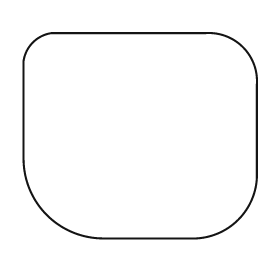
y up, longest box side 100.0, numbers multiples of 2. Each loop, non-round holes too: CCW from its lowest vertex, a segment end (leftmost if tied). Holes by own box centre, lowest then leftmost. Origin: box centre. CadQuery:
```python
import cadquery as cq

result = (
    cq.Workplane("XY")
    .moveTo(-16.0, -44.0)
    .lineTo(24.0, -44.0)
    .threePointArc((42.0, -36.0), (50.0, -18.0))
    .lineTo(50.0, 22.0)
    .threePointArc((44.0, 38.0), (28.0, 44.0))
    .lineTo(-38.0, 44.0)
    .threePointArc((-46.0, 40.0), (-50.0, 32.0))
    .lineTo(-50.0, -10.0)
    .threePointArc((-40.0, -34.0), (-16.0, -44.0))
    .close()
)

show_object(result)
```